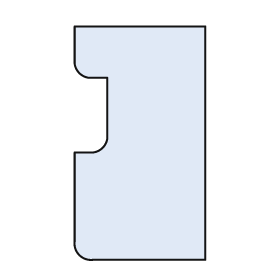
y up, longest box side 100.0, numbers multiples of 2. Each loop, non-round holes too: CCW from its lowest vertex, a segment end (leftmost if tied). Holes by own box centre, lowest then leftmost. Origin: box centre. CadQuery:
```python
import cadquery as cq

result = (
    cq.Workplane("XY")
    .moveTo(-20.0, -50.0)
    .lineTo(28.0, -50.0)
    .lineTo(28.0, 50.0)
    .lineTo(-28.0, 50.0)
    .lineTo(-28.0, 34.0)
    .threePointArc((-26.0, 30.0), (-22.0, 28.0))
    .lineTo(-14.0, 28.0)
    .lineTo(-14.0, 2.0)
    .threePointArc((-16.0, -2.0), (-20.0, -4.0))
    .lineTo(-28.0, -4.0)
    .lineTo(-28.0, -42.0)
    .threePointArc((-26.0, -48.0), (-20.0, -50.0))
    .close()
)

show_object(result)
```